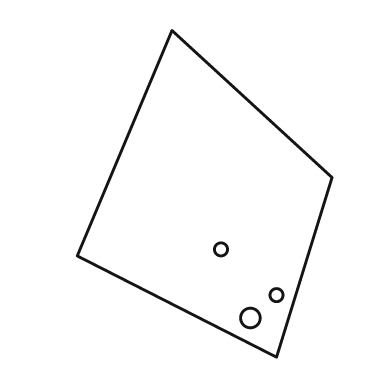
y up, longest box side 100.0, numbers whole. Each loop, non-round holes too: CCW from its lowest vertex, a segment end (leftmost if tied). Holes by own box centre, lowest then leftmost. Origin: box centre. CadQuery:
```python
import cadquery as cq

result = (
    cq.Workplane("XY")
    .moveTo(22.0, -50.0)
    .lineTo(39.0, 5.0)
    .lineTo(-10.0, 50.0)
    .lineTo(-39.0, -19.0)
    .close()
    .moveTo(14.0, -38.0)
    .circle(3.0)
    .moveTo(22.0, -31.0)
    .circle(2.0)
    .moveTo(5.0, -17.0)
    .circle(2.0)
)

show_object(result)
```